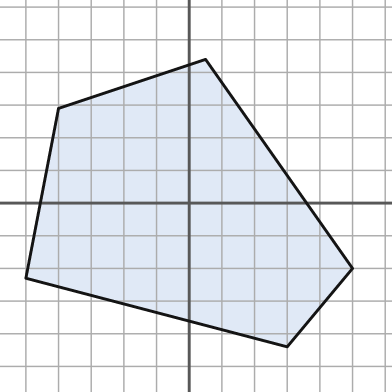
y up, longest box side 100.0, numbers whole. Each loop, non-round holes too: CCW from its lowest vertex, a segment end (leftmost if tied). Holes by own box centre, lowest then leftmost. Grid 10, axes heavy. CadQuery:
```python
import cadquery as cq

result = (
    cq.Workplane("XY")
    .moveTo(30.0, -44.0)
    .lineTo(50.0, -20.0)
    .lineTo(5.0, 44.0)
    .lineTo(-40.0, 29.0)
    .lineTo(-50.0, -23.0)
    .close()
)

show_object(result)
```